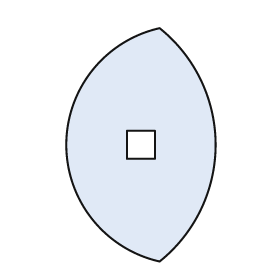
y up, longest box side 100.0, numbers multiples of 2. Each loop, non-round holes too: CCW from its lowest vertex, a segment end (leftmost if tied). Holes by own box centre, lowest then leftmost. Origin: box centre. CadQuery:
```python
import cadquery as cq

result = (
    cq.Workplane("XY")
    .moveTo(8.0, -50.0)
    .threePointArc((32.0, 0.0), (8.0, 50.0))
    .threePointArc((-32.0, 0.0), (8.0, -50.0))
    .close()
    .moveTo(-6.0, -6.0)
    .lineTo(6.0, -6.0)
    .lineTo(6.0, 6.0)
    .lineTo(-6.0, 6.0)
    .close()
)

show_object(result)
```